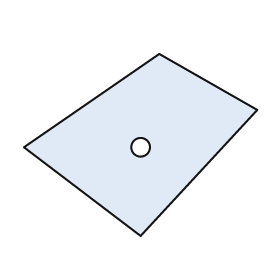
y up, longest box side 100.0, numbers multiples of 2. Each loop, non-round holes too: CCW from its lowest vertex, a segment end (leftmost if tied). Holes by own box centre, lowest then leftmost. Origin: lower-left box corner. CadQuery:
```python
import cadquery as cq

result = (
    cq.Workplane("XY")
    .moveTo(50.0, 0.0)
    .lineTo(100.0, 54.0)
    .lineTo(58.0, 78.0)
    .lineTo(0.0, 38.0)
    .close()
    .moveTo(50.0, 38.0)
    .circle(4.0)
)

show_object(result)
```